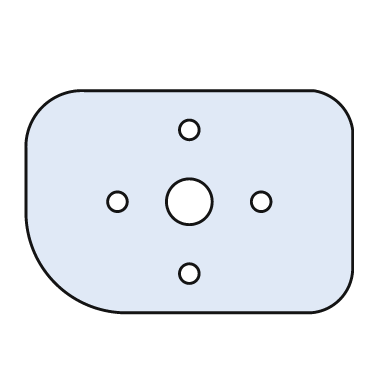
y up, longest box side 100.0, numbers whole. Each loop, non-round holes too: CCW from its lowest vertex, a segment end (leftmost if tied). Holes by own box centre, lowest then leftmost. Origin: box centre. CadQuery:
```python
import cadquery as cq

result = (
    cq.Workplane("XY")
    .moveTo(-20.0, -34.0)
    .lineTo(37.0, -34.0)
    .threePointArc((46.0, -30.0), (50.0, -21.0))
    .lineTo(50.0, 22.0)
    .threePointArc((46.0, 30.0), (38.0, 34.0))
    .lineTo(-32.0, 34.0)
    .threePointArc((-45.0, 29.0), (-50.0, 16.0))
    .lineTo(-50.0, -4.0)
    .threePointArc((-41.0, -25.0), (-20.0, -34.0))
    .close()
    .moveTo(0.0, -22.0)
    .circle(3.0)
    .moveTo(-22.0, 0.0)
    .circle(3.0)
    .moveTo(0.0, 0.0)
    .circle(7.0)
    .moveTo(22.0, 0.0)
    .circle(3.0)
    .moveTo(0.0, 22.0)
    .circle(3.0)
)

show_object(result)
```